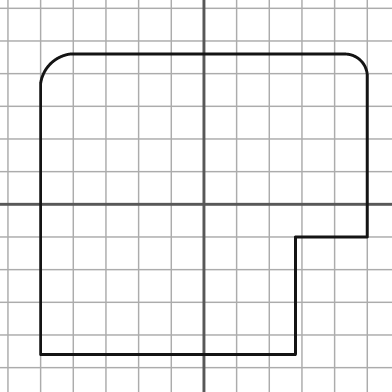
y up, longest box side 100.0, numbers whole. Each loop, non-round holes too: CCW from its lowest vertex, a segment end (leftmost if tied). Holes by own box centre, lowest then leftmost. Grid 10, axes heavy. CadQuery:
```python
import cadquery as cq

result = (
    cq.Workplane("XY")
    .moveTo(-50.0, -46.0)
    .lineTo(28.0, -46.0)
    .lineTo(28.0, -10.0)
    .lineTo(50.0, -10.0)
    .lineTo(50.0, 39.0)
    .threePointArc((48.0, 44.0), (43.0, 46.0))
    .lineTo(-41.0, 46.0)
    .threePointArc((-47.0, 43.0), (-50.0, 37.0))
    .close()
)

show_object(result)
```